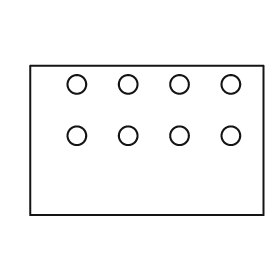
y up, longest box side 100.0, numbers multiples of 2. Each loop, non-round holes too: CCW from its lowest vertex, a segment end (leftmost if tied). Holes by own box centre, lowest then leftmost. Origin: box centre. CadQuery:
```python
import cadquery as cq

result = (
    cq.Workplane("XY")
    .moveTo(-50.0, -32.0)
    .lineTo(50.0, -32.0)
    .lineTo(50.0, 32.0)
    .lineTo(-50.0, 32.0)
    .close()
    .moveTo(-30.0, 2.0)
    .circle(4.0)
    .moveTo(-8.0, 2.0)
    .circle(4.0)
    .moveTo(14.0, 2.0)
    .circle(4.0)
    .moveTo(36.0, 2.0)
    .circle(4.0)
    .moveTo(-30.0, 24.0)
    .circle(4.0)
    .moveTo(-8.0, 24.0)
    .circle(4.0)
    .moveTo(14.0, 24.0)
    .circle(4.0)
    .moveTo(36.0, 24.0)
    .circle(4.0)
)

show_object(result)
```